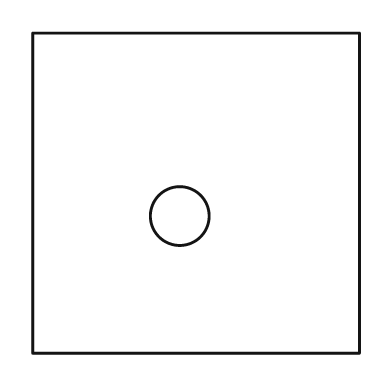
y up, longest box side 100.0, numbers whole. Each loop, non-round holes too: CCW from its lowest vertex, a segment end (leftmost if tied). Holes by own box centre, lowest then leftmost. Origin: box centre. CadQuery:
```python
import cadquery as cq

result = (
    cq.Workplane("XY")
    .moveTo(-50.0, -49.0)
    .lineTo(50.0, -49.0)
    .lineTo(50.0, 49.0)
    .lineTo(-50.0, 49.0)
    .close()
    .moveTo(-5.0, -7.0)
    .circle(9.0)
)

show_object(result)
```